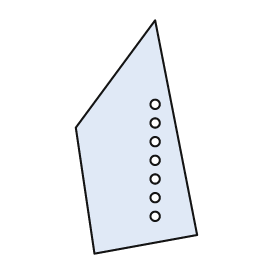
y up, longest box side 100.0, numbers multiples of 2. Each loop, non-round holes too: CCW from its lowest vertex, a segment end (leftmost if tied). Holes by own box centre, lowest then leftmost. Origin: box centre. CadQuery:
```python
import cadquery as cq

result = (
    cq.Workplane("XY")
    .moveTo(-18.0, -50.0)
    .lineTo(26.0, -42.0)
    .lineTo(8.0, 50.0)
    .lineTo(-26.0, 4.0)
    .close()
    .moveTo(8.0, -34.0)
    .circle(2.0)
    .moveTo(8.0, -26.0)
    .circle(2.0)
    .moveTo(8.0, -18.0)
    .circle(2.0)
    .moveTo(8.0, -10.0)
    .circle(2.0)
    .moveTo(8.0, -2.0)
    .circle(2.0)
    .moveTo(8.0, 6.0)
    .circle(2.0)
    .moveTo(8.0, 14.0)
    .circle(2.0)
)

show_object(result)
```